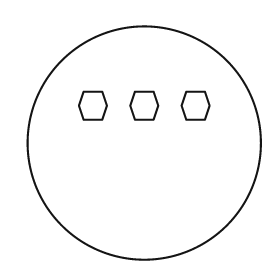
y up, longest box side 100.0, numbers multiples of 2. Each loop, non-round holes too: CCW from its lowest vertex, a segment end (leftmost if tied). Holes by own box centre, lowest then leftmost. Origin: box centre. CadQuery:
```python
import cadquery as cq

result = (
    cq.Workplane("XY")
    .moveTo(0.0, 0.0)
    .circle(50.0)
    .moveTo(-26.0, 10.0)
    .lineTo(-18.0, 10.0)
    .lineTo(-16.0, 16.0)
    .lineTo(-18.0, 22.0)
    .lineTo(-26.0, 22.0)
    .lineTo(-28.0, 16.0)
    .close()
    .moveTo(-4.0, 10.0)
    .lineTo(4.0, 10.0)
    .lineTo(6.0, 16.0)
    .lineTo(4.0, 22.0)
    .lineTo(-4.0, 22.0)
    .lineTo(-6.0, 16.0)
    .close()
    .moveTo(18.0, 10.0)
    .lineTo(26.0, 10.0)
    .lineTo(28.0, 16.0)
    .lineTo(26.0, 22.0)
    .lineTo(18.0, 22.0)
    .lineTo(16.0, 16.0)
    .close()
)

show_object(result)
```